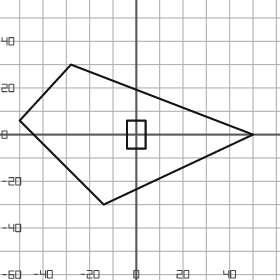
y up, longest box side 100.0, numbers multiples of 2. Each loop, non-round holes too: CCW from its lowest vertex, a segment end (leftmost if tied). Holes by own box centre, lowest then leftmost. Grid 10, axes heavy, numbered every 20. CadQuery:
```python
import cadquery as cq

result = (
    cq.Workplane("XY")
    .moveTo(-14.0, -30.0)
    .lineTo(50.0, 0.0)
    .lineTo(-28.0, 30.0)
    .lineTo(-50.0, 6.0)
    .close()
    .moveTo(-4.0, -6.0)
    .lineTo(4.0, -6.0)
    .lineTo(4.0, 6.0)
    .lineTo(-4.0, 6.0)
    .close()
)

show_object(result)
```